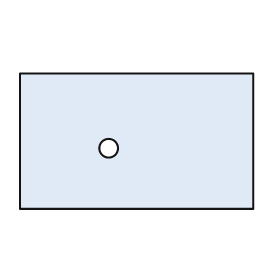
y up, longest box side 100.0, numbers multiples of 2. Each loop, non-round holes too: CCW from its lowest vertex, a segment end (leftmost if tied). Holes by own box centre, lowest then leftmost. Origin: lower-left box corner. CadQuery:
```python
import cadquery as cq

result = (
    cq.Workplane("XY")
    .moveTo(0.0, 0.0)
    .lineTo(100.0, 0.0)
    .lineTo(100.0, 58.0)
    .lineTo(0.0, 58.0)
    .close()
    .moveTo(38.0, 26.0)
    .circle(4.0)
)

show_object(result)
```